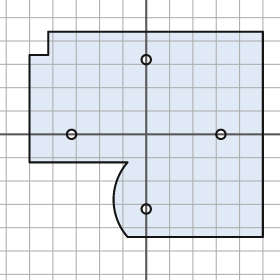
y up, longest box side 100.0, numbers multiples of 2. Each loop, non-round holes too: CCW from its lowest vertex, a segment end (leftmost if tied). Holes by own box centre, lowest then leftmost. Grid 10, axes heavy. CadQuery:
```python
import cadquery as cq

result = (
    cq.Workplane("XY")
    .moveTo(-8.0, -44.0)
    .lineTo(50.0, -44.0)
    .lineTo(50.0, 44.0)
    .lineTo(-42.0, 44.0)
    .lineTo(-42.0, 34.0)
    .lineTo(-50.0, 34.0)
    .lineTo(-50.0, -12.0)
    .lineTo(-8.0, -12.0)
    .threePointArc((-14.0, -28.0), (-8.0, -44.0))
    .close()
    .moveTo(0.0, -32.0)
    .circle(2.0)
    .moveTo(-32.0, 0.0)
    .circle(2.0)
    .moveTo(32.0, 0.0)
    .circle(2.0)
    .moveTo(0.0, 32.0)
    .circle(2.0)
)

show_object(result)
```